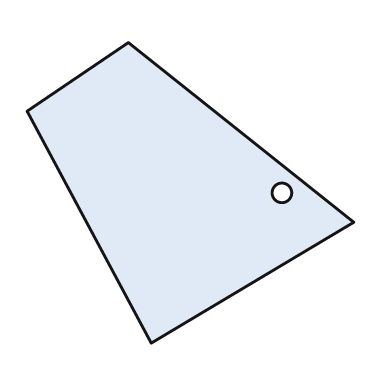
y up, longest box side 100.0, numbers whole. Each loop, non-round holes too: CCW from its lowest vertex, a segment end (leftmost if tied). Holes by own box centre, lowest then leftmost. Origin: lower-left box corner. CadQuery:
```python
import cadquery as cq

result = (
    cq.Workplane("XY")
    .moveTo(38.0, 0.0)
    .lineTo(100.0, 37.0)
    .lineTo(31.0, 92.0)
    .lineTo(0.0, 71.0)
    .close()
    .moveTo(78.0, 46.0)
    .circle(3.0)
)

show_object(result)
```